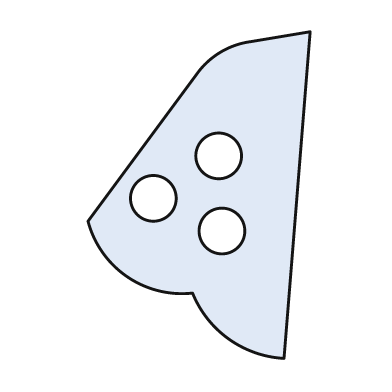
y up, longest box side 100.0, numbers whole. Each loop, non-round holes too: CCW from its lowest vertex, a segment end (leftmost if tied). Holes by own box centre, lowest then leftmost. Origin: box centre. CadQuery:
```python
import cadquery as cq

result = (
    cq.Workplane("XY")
    .moveTo(26.0, -50.0)
    .lineTo(34.0, 50.0)
    .lineTo(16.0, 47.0)
    .threePointArc((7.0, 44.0), (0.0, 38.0))
    .lineTo(-34.0, -8.0)
    .threePointArc((-22.0, -25.0), (-2.0, -30.0))
    .threePointArc((9.0, -44.0), (26.0, -50.0))
    .close()
    .moveTo(7.0, -11.0)
    .circle(7.0)
    .moveTo(-14.0, -1.0)
    .circle(7.0)
    .moveTo(6.0, 12.0)
    .circle(7.0)
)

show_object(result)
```